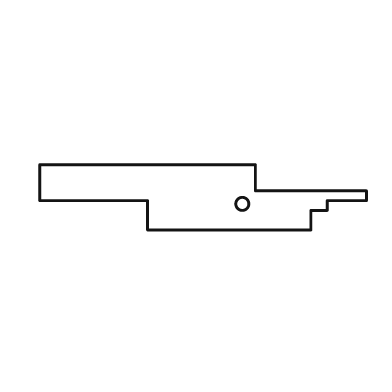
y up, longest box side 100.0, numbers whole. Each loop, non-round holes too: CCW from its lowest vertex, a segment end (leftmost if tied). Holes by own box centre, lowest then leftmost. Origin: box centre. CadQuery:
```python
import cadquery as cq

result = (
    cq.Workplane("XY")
    .moveTo(-17.0, -10.0)
    .lineTo(33.0, -10.0)
    .lineTo(33.0, -4.0)
    .lineTo(38.0, -4.0)
    .lineTo(38.0, -1.0)
    .lineTo(50.0, -1.0)
    .lineTo(50.0, 2.0)
    .lineTo(16.0, 2.0)
    .lineTo(16.0, 10.0)
    .lineTo(-50.0, 10.0)
    .lineTo(-50.0, -1.0)
    .lineTo(-17.0, -1.0)
    .close()
    .moveTo(12.0, -2.0)
    .circle(2.0)
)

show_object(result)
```